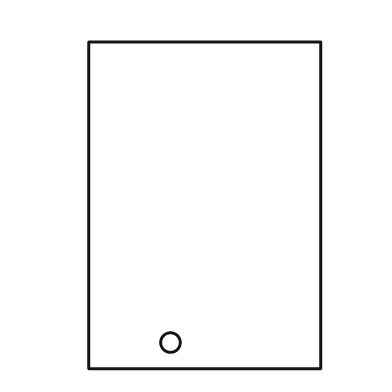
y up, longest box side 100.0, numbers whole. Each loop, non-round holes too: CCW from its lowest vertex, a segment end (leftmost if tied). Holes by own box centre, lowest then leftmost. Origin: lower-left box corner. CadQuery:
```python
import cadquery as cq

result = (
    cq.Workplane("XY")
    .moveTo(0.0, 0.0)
    .lineTo(71.0, 0.0)
    .lineTo(71.0, 100.0)
    .lineTo(0.0, 100.0)
    .close()
    .moveTo(25.0, 8.0)
    .circle(3.0)
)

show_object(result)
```